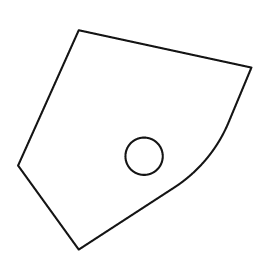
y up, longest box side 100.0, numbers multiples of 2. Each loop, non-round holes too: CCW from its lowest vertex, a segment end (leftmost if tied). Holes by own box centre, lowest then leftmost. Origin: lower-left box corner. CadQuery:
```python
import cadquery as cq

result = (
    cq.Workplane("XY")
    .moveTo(26.0, 0.0)
    .lineTo(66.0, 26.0)
    .threePointArc((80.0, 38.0), (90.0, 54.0))
    .lineTo(100.0, 78.0)
    .lineTo(26.0, 94.0)
    .lineTo(0.0, 36.0)
    .close()
    .moveTo(54.0, 40.0)
    .circle(8.0)
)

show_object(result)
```